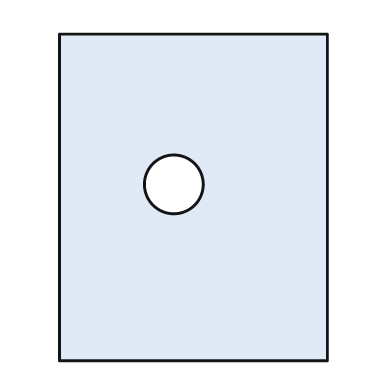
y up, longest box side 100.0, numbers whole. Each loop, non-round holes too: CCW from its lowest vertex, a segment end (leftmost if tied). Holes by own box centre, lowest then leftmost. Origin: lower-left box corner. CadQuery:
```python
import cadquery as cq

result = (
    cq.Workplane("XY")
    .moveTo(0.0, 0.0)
    .lineTo(82.0, 0.0)
    .lineTo(82.0, 100.0)
    .lineTo(0.0, 100.0)
    .close()
    .moveTo(35.0, 54.0)
    .circle(9.0)
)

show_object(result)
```